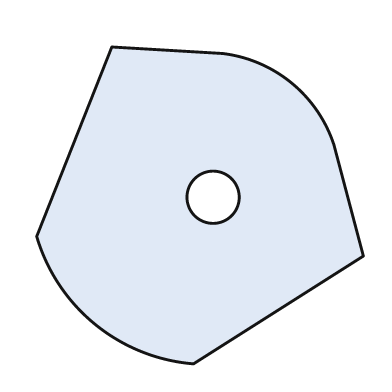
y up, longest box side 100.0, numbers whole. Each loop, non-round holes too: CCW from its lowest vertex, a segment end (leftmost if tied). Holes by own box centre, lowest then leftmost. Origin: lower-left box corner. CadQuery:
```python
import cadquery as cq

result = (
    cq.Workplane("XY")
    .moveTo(48.0, 0.0)
    .lineTo(100.0, 33.0)
    .lineTo(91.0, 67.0)
    .threePointArc((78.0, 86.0), (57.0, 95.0))
    .lineTo(23.0, 97.0)
    .lineTo(0.0, 39.0)
    .threePointArc((18.0, 12.0), (48.0, 0.0))
    .close()
    .moveTo(54.0, 51.0)
    .circle(8.0)
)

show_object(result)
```